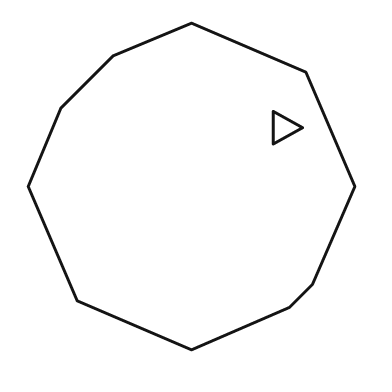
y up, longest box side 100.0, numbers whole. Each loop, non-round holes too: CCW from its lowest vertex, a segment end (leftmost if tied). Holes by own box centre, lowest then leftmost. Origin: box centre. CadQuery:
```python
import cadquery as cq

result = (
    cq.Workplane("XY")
    .moveTo(0.0, -50.0)
    .lineTo(30.0, -37.0)
    .lineTo(37.0, -30.0)
    .lineTo(50.0, 0.0)
    .lineTo(35.0, 35.0)
    .lineTo(0.0, 50.0)
    .lineTo(-24.0, 40.0)
    .lineTo(-40.0, 24.0)
    .lineTo(-50.0, 0.0)
    .lineTo(-35.0, -35.0)
    .close()
    .moveTo(25.0, 13.0)
    .lineTo(34.0, 18.0)
    .lineTo(25.0, 23.0)
    .close()
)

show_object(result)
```